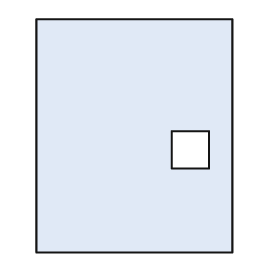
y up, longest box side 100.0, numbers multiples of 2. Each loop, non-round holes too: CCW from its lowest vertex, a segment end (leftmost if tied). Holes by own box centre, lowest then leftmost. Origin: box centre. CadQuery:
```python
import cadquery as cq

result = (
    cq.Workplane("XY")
    .moveTo(-42.0, -50.0)
    .lineTo(42.0, -50.0)
    .lineTo(42.0, 50.0)
    .lineTo(-42.0, 50.0)
    .close()
    .moveTo(16.0, -14.0)
    .lineTo(32.0, -14.0)
    .lineTo(32.0, 2.0)
    .lineTo(16.0, 2.0)
    .close()
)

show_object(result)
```